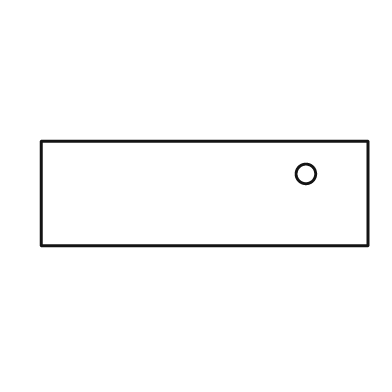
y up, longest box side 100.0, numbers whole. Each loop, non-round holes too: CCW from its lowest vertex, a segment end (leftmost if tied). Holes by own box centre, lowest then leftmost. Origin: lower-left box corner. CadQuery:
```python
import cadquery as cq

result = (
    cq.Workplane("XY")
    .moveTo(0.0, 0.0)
    .lineTo(100.0, 0.0)
    .lineTo(100.0, 32.0)
    .lineTo(0.0, 32.0)
    .close()
    .moveTo(81.0, 22.0)
    .circle(3.0)
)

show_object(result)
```